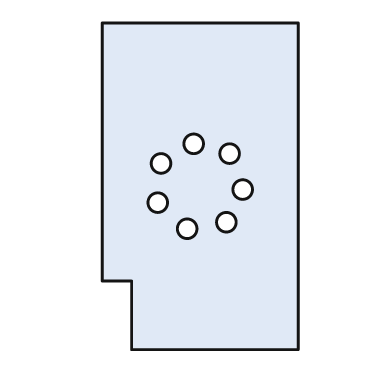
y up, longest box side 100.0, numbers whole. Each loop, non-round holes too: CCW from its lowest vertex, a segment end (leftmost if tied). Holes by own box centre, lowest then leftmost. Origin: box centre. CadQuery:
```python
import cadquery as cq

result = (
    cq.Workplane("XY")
    .moveTo(-21.0, -50.0)
    .lineTo(30.0, -50.0)
    .lineTo(30.0, 50.0)
    .lineTo(-30.0, 50.0)
    .lineTo(-30.0, -29.0)
    .lineTo(-21.0, -29.0)
    .close()
    .moveTo(-4.0, -13.0)
    .circle(3.0)
    .moveTo(8.0, -11.0)
    .circle(3.0)
    .moveTo(-13.0, -5.0)
    .circle(3.0)
    .moveTo(13.0, -1.0)
    .circle(3.0)
    .moveTo(-12.0, 7.0)
    .circle(3.0)
    .moveTo(9.0, 10.0)
    .circle(3.0)
    .moveTo(-2.0, 13.0)
    .circle(3.0)
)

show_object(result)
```